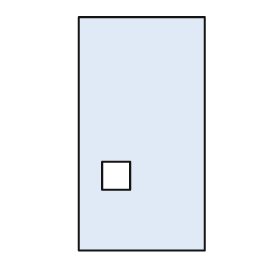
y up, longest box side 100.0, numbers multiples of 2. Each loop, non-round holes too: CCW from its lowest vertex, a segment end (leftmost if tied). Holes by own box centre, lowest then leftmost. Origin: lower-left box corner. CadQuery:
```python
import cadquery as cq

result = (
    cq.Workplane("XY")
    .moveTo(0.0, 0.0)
    .lineTo(54.0, 0.0)
    .lineTo(54.0, 100.0)
    .lineTo(0.0, 100.0)
    .close()
    .moveTo(10.0, 26.0)
    .lineTo(22.0, 26.0)
    .lineTo(22.0, 38.0)
    .lineTo(10.0, 38.0)
    .close()
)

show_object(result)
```